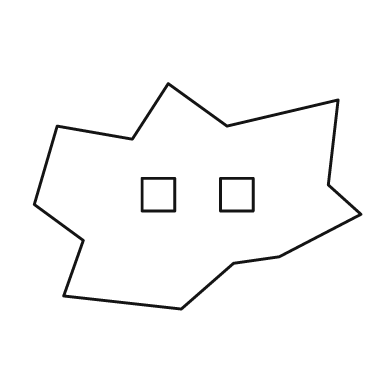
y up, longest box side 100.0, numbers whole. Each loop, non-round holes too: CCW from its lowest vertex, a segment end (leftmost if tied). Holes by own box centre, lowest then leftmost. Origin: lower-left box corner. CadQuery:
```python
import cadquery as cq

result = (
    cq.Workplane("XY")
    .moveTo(45.0, 0.0)
    .lineTo(61.0, 14.0)
    .lineTo(75.0, 16.0)
    .lineTo(100.0, 29.0)
    .lineTo(90.0, 38.0)
    .lineTo(93.0, 64.0)
    .lineTo(59.0, 56.0)
    .lineTo(41.0, 69.0)
    .lineTo(30.0, 52.0)
    .lineTo(7.0, 56.0)
    .lineTo(0.0, 32.0)
    .lineTo(15.0, 21.0)
    .lineTo(9.0, 4.0)
    .close()
    .moveTo(33.0, 30.0)
    .lineTo(43.0, 30.0)
    .lineTo(43.0, 40.0)
    .lineTo(33.0, 40.0)
    .close()
    .moveTo(57.0, 30.0)
    .lineTo(67.0, 30.0)
    .lineTo(67.0, 40.0)
    .lineTo(57.0, 40.0)
    .close()
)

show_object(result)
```